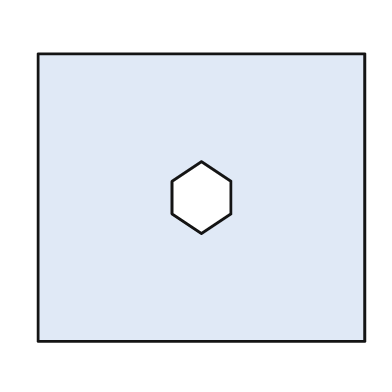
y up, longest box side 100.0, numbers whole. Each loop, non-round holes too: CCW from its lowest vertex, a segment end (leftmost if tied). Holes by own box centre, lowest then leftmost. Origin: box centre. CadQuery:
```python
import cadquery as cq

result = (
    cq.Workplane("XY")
    .moveTo(-50.0, -44.0)
    .lineTo(50.0, -44.0)
    .lineTo(50.0, 44.0)
    .lineTo(-50.0, 44.0)
    .close()
    .moveTo(0.0, -11.0)
    .lineTo(9.0, -5.0)
    .lineTo(9.0, 5.0)
    .lineTo(0.0, 11.0)
    .lineTo(-9.0, 5.0)
    .lineTo(-9.0, -5.0)
    .close()
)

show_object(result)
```